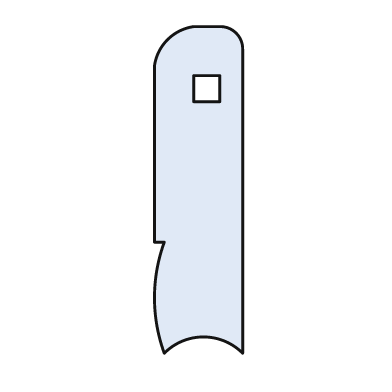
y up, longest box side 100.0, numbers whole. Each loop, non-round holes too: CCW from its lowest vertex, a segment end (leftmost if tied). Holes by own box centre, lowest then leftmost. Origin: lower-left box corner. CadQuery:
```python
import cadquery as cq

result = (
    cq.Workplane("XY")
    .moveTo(3.0, 0.0)
    .threePointArc((15.0, 5.0), (27.0, 0.0))
    .lineTo(27.0, 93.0)
    .threePointArc((25.0, 98.0), (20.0, 100.0))
    .lineTo(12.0, 100.0)
    .threePointArc((4.0, 96.0), (0.0, 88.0))
    .lineTo(0.0, 34.0)
    .lineTo(3.0, 34.0)
    .threePointArc((0.0, 17.0), (3.0, 0.0))
    .close()
    .moveTo(12.0, 77.0)
    .lineTo(20.0, 77.0)
    .lineTo(20.0, 85.0)
    .lineTo(12.0, 85.0)
    .close()
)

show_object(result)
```